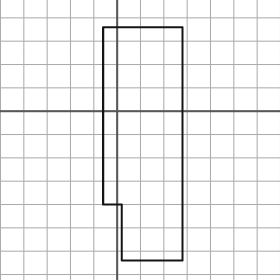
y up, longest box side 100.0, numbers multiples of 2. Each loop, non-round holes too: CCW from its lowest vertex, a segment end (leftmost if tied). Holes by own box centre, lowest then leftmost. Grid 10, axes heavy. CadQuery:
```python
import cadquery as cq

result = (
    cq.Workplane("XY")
    .moveTo(2.0, -64.0)
    .lineTo(28.0, -64.0)
    .lineTo(28.0, 36.0)
    .lineTo(-6.0, 36.0)
    .lineTo(-6.0, -40.0)
    .lineTo(2.0, -40.0)
    .close()
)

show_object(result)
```